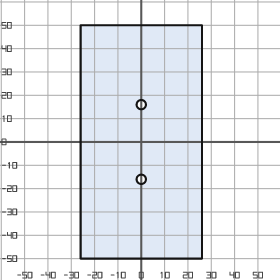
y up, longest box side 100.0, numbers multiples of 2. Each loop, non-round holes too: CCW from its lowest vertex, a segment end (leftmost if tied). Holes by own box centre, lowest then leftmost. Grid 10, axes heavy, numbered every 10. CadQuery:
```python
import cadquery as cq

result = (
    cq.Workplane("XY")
    .moveTo(-26.0, -50.0)
    .lineTo(26.0, -50.0)
    .lineTo(26.0, 50.0)
    .lineTo(-26.0, 50.0)
    .close()
    .moveTo(0.0, -16.0)
    .circle(2.0)
    .moveTo(0.0, 16.0)
    .circle(2.0)
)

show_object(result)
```